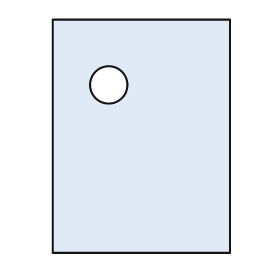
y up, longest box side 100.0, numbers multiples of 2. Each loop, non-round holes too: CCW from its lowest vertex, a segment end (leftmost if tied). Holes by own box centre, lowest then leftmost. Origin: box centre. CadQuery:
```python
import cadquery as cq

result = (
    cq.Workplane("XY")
    .moveTo(-38.0, -50.0)
    .lineTo(38.0, -50.0)
    .lineTo(38.0, 50.0)
    .lineTo(-38.0, 50.0)
    .close()
    .moveTo(-14.0, 22.0)
    .circle(8.0)
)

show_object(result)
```